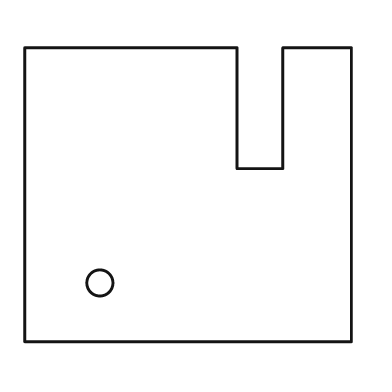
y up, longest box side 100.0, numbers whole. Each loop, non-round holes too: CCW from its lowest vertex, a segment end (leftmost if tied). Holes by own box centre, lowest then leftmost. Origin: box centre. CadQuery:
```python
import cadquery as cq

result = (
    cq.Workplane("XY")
    .moveTo(-50.0, -45.0)
    .lineTo(50.0, -45.0)
    .lineTo(50.0, 45.0)
    .lineTo(29.0, 45.0)
    .lineTo(29.0, 8.0)
    .lineTo(15.0, 8.0)
    .lineTo(15.0, 45.0)
    .lineTo(-50.0, 45.0)
    .close()
    .moveTo(-27.0, -27.0)
    .circle(4.0)
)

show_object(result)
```